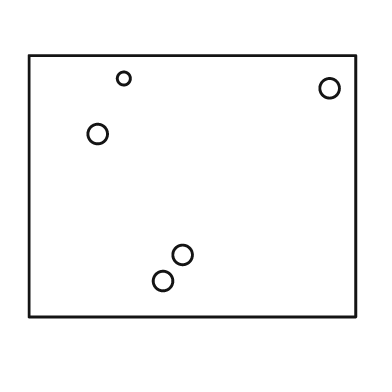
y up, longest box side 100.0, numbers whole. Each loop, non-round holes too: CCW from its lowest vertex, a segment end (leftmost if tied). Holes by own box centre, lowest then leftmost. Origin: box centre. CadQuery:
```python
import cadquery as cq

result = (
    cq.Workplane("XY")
    .moveTo(-50.0, -40.0)
    .lineTo(50.0, -40.0)
    .lineTo(50.0, 40.0)
    .lineTo(-50.0, 40.0)
    .close()
    .moveTo(-9.0, -29.0)
    .circle(3.0)
    .moveTo(-3.0, -21.0)
    .circle(3.0)
    .moveTo(-29.0, 16.0)
    .circle(3.0)
    .moveTo(42.0, 30.0)
    .circle(3.0)
    .moveTo(-21.0, 33.0)
    .circle(2.0)
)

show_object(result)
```